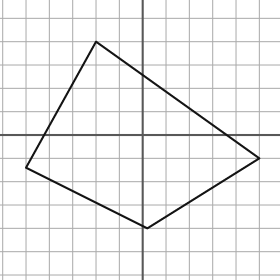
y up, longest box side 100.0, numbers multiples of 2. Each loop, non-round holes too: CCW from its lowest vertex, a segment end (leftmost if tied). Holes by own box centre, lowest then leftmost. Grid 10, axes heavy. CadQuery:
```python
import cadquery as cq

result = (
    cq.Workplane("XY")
    .moveTo(2.0, -40.0)
    .lineTo(50.0, -10.0)
    .lineTo(-20.0, 40.0)
    .lineTo(-50.0, -14.0)
    .close()
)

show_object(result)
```